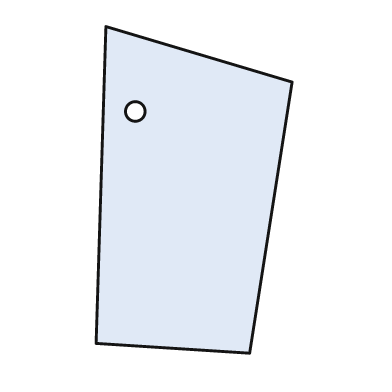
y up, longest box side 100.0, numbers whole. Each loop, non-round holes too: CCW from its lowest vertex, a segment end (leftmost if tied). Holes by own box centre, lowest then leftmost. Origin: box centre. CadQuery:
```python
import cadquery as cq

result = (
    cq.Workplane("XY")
    .moveTo(17.0, -50.0)
    .lineTo(30.0, 33.0)
    .lineTo(-27.0, 50.0)
    .lineTo(-30.0, -47.0)
    .close()
    .moveTo(-18.0, 24.0)
    .circle(3.0)
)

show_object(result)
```